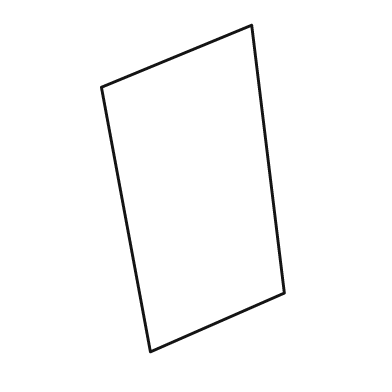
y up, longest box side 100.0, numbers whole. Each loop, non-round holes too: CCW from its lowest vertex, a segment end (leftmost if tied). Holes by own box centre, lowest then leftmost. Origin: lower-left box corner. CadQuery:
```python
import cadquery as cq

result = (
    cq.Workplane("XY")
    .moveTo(15.0, 0.0)
    .lineTo(56.0, 18.0)
    .lineTo(46.0, 100.0)
    .lineTo(0.0, 81.0)
    .close()
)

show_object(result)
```